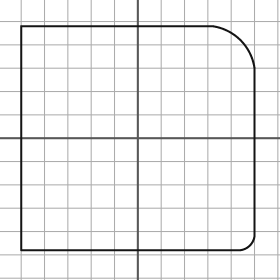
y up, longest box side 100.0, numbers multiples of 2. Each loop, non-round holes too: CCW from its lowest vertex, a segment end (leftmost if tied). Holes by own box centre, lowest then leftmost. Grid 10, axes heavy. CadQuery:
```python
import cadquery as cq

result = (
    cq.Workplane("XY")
    .moveTo(-50.0, -48.0)
    .lineTo(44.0, -48.0)
    .threePointArc((48.0, -46.0), (50.0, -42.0))
    .lineTo(50.0, 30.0)
    .threePointArc((44.0, 42.0), (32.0, 48.0))
    .lineTo(-50.0, 48.0)
    .close()
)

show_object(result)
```